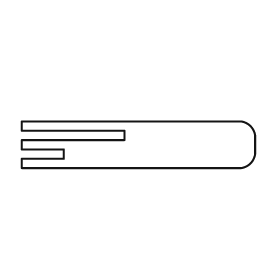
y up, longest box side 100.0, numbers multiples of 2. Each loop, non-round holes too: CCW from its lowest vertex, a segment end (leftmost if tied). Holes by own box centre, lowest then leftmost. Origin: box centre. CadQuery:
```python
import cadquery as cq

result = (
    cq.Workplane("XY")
    .moveTo(-50.0, -10.0)
    .lineTo(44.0, -10.0)
    .threePointArc((48.0, -8.0), (50.0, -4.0))
    .lineTo(50.0, 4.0)
    .threePointArc((48.0, 8.0), (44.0, 10.0))
    .lineTo(-50.0, 10.0)
    .lineTo(-50.0, 6.0)
    .lineTo(-6.0, 6.0)
    .lineTo(-6.0, 2.0)
    .lineTo(-50.0, 2.0)
    .lineTo(-50.0, -2.0)
    .lineTo(-32.0, -2.0)
    .lineTo(-32.0, -6.0)
    .lineTo(-50.0, -6.0)
    .close()
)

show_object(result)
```